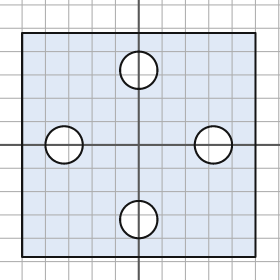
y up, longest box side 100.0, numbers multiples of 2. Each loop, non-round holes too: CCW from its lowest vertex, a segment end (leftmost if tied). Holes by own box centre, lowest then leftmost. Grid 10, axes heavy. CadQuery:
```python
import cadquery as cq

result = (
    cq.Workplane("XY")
    .moveTo(-50.0, -48.0)
    .lineTo(50.0, -48.0)
    .lineTo(50.0, 48.0)
    .lineTo(-50.0, 48.0)
    .close()
    .moveTo(0.0, -32.0)
    .circle(8.0)
    .moveTo(-32.0, 0.0)
    .circle(8.0)
    .moveTo(32.0, 0.0)
    .circle(8.0)
    .moveTo(0.0, 32.0)
    .circle(8.0)
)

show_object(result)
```